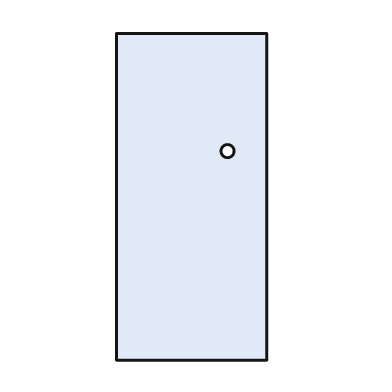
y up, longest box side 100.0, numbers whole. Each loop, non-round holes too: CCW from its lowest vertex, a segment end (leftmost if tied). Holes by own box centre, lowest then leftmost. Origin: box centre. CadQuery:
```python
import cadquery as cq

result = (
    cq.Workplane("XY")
    .moveTo(-23.0, -50.0)
    .lineTo(23.0, -50.0)
    .lineTo(23.0, 50.0)
    .lineTo(-23.0, 50.0)
    .close()
    .moveTo(11.0, 14.0)
    .circle(2.0)
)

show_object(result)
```